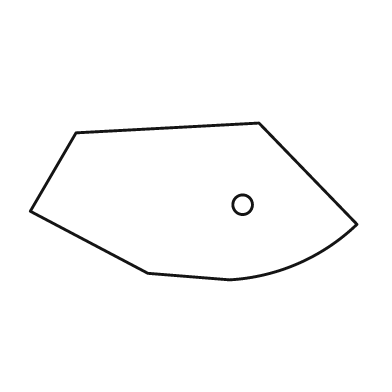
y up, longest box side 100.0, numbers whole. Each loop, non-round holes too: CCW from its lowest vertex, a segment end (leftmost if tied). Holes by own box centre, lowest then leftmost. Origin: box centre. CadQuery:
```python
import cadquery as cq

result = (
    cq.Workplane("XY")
    .moveTo(11.0, -24.0)
    .threePointArc((32.0, -19.0), (50.0, -7.0))
    .lineTo(20.0, 24.0)
    .lineTo(-36.0, 21.0)
    .lineTo(-50.0, -3.0)
    .lineTo(-14.0, -22.0)
    .close()
    .moveTo(15.0, -1.0)
    .circle(3.0)
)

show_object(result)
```